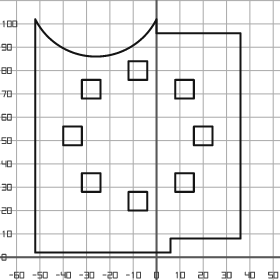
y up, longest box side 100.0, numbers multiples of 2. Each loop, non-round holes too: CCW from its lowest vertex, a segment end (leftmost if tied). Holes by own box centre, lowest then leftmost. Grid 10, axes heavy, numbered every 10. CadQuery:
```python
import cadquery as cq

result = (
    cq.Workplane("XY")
    .moveTo(-52.0, 2.0)
    .lineTo(6.0, 2.0)
    .lineTo(6.0, 8.0)
    .lineTo(36.0, 8.0)
    .lineTo(36.0, 96.0)
    .lineTo(0.0, 96.0)
    .lineTo(0.0, 102.0)
    .threePointArc((-26.0, 86.0), (-52.0, 102.0))
    .close()
    .moveTo(-12.0, 20.0)
    .lineTo(-4.0, 20.0)
    .lineTo(-4.0, 28.0)
    .lineTo(-12.0, 28.0)
    .close()
    .moveTo(-32.0, 28.0)
    .lineTo(-24.0, 28.0)
    .lineTo(-24.0, 36.0)
    .lineTo(-32.0, 36.0)
    .close()
    .moveTo(8.0, 28.0)
    .lineTo(16.0, 28.0)
    .lineTo(16.0, 36.0)
    .lineTo(8.0, 36.0)
    .close()
    .moveTo(-40.0, 48.0)
    .lineTo(-32.0, 48.0)
    .lineTo(-32.0, 56.0)
    .lineTo(-40.0, 56.0)
    .close()
    .moveTo(16.0, 48.0)
    .lineTo(24.0, 48.0)
    .lineTo(24.0, 56.0)
    .lineTo(16.0, 56.0)
    .close()
    .moveTo(-32.0, 68.0)
    .lineTo(-24.0, 68.0)
    .lineTo(-24.0, 76.0)
    .lineTo(-32.0, 76.0)
    .close()
    .moveTo(8.0, 68.0)
    .lineTo(16.0, 68.0)
    .lineTo(16.0, 76.0)
    .lineTo(8.0, 76.0)
    .close()
    .moveTo(-12.0, 76.0)
    .lineTo(-4.0, 76.0)
    .lineTo(-4.0, 84.0)
    .lineTo(-12.0, 84.0)
    .close()
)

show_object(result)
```